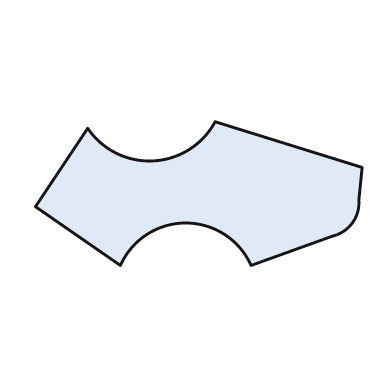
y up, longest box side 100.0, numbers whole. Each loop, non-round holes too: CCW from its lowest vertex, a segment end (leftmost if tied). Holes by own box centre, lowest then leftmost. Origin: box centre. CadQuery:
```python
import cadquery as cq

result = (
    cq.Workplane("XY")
    .moveTo(-24.0, -22.0)
    .threePointArc((-4.0, -9.0), (16.0, -22.0))
    .lineTo(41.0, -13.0)
    .threePointArc((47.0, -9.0), (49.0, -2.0))
    .lineTo(50.0, 8.0)
    .lineTo(5.0, 22.0)
    .threePointArc((-14.0, 10.0), (-34.0, 20.0))
    .lineTo(-50.0, -4.0)
    .close()
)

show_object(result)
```